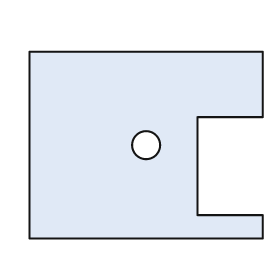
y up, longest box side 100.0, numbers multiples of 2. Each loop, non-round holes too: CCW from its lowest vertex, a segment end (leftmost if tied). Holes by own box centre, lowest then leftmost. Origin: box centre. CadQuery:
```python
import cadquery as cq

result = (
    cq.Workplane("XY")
    .moveTo(-50.0, -40.0)
    .lineTo(50.0, -40.0)
    .lineTo(50.0, -30.0)
    .lineTo(22.0, -30.0)
    .lineTo(22.0, 12.0)
    .lineTo(50.0, 12.0)
    .lineTo(50.0, 40.0)
    .lineTo(-50.0, 40.0)
    .close()
    .moveTo(0.0, 0.0)
    .circle(6.0)
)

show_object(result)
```